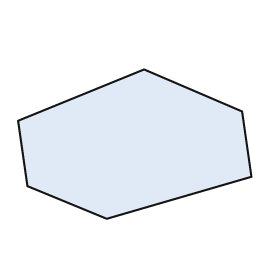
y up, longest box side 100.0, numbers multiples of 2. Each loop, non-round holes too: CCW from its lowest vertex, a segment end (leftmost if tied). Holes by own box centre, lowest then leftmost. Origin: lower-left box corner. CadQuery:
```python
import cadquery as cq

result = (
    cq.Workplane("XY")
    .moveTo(38.0, 0.0)
    .lineTo(100.0, 18.0)
    .lineTo(96.0, 46.0)
    .lineTo(54.0, 64.0)
    .lineTo(0.0, 42.0)
    .lineTo(4.0, 14.0)
    .close()
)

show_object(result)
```